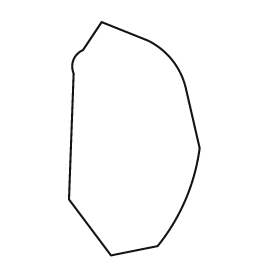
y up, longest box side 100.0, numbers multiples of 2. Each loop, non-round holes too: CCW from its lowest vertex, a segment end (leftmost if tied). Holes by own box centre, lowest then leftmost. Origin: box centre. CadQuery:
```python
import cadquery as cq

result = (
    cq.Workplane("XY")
    .moveTo(-10.0, -50.0)
    .lineTo(10.0, -46.0)
    .threePointArc((22.0, -26.0), (28.0, -4.0))
    .lineTo(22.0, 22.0)
    .threePointArc((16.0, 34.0), (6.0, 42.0))
    .lineTo(-14.0, 50.0)
    .lineTo(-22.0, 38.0)
    .threePointArc((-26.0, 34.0), (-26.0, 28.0))
    .lineTo(-28.0, -26.0)
    .close()
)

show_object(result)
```